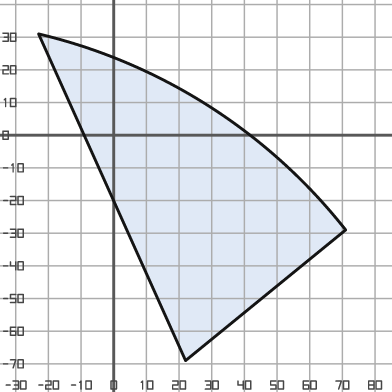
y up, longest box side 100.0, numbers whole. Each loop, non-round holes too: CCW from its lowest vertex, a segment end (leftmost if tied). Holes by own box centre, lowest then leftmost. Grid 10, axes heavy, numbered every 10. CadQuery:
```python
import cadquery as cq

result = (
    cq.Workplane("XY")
    .moveTo(22.0, -69.0)
    .lineTo(71.0, -29.0)
    .threePointArc((29.0, 9.0), (-23.0, 31.0))
    .close()
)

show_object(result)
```